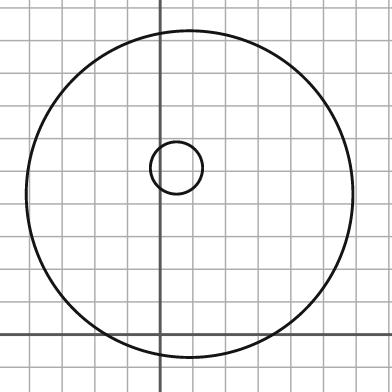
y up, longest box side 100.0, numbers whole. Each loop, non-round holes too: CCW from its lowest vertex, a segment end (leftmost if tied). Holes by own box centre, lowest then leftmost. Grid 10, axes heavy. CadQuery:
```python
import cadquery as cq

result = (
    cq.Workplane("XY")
    .moveTo(9.0, 43.0)
    .circle(50.0)
    .moveTo(5.0, 51.0)
    .circle(8.0)
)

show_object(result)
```